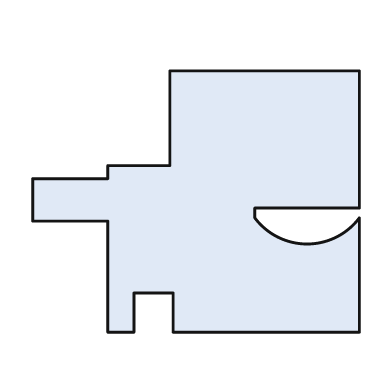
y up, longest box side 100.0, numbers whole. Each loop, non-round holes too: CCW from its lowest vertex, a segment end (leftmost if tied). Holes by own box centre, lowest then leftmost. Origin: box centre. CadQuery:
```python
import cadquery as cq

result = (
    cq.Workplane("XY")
    .moveTo(-27.0, -40.0)
    .lineTo(-19.0, -40.0)
    .lineTo(-19.0, -28.0)
    .lineTo(-7.0, -28.0)
    .lineTo(-7.0, -40.0)
    .lineTo(50.0, -40.0)
    .lineTo(50.0, -5.0)
    .threePointArc((34.0, -13.0), (18.0, -5.0))
    .lineTo(18.0, -2.0)
    .lineTo(50.0, -2.0)
    .lineTo(50.0, 40.0)
    .lineTo(-8.0, 40.0)
    .lineTo(-8.0, 11.0)
    .lineTo(-27.0, 11.0)
    .lineTo(-27.0, 7.0)
    .lineTo(-50.0, 7.0)
    .lineTo(-50.0, -6.0)
    .lineTo(-27.0, -6.0)
    .close()
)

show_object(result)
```